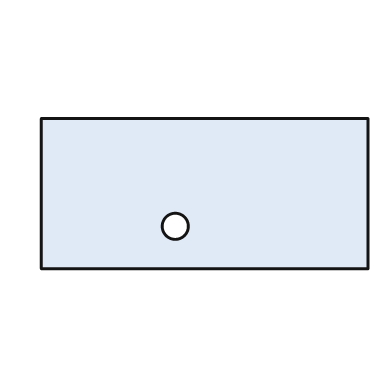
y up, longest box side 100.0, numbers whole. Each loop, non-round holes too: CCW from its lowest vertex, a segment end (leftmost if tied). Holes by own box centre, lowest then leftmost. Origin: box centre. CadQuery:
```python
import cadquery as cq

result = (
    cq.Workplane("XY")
    .moveTo(-50.0, -23.0)
    .lineTo(50.0, -23.0)
    .lineTo(50.0, 23.0)
    .lineTo(-50.0, 23.0)
    .close()
    .moveTo(-9.0, -10.0)
    .circle(4.0)
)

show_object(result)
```